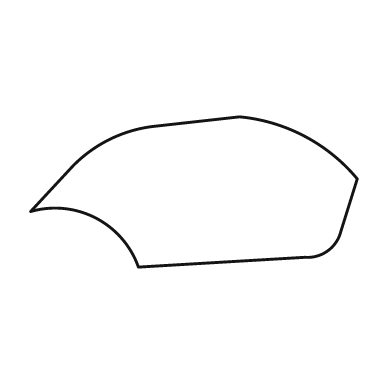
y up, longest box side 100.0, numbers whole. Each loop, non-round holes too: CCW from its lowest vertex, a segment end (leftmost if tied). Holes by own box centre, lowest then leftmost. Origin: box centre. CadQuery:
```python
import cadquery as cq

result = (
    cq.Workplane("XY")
    .moveTo(-17.0, -23.0)
    .lineTo(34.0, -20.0)
    .threePointArc((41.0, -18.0), (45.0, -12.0))
    .lineTo(50.0, 4.0)
    .threePointArc((34.0, 17.0), (14.0, 23.0))
    .lineTo(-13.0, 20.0)
    .threePointArc((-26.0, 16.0), (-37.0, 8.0))
    .lineTo(-50.0, -6.0)
    .threePointArc((-30.0, -8.0), (-17.0, -23.0))
    .close()
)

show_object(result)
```